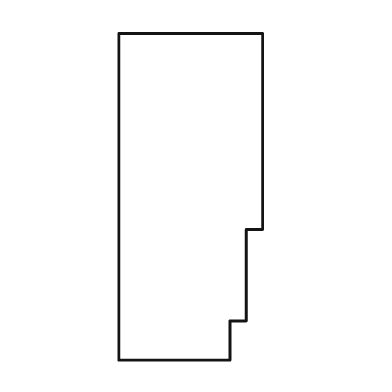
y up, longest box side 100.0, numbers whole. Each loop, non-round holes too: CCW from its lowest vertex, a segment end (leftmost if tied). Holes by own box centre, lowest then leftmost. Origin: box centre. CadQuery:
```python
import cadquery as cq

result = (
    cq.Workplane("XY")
    .moveTo(-22.0, -50.0)
    .lineTo(12.0, -50.0)
    .lineTo(12.0, -38.0)
    .lineTo(17.0, -38.0)
    .lineTo(17.0, -10.0)
    .lineTo(22.0, -10.0)
    .lineTo(22.0, 50.0)
    .lineTo(-22.0, 50.0)
    .close()
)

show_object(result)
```